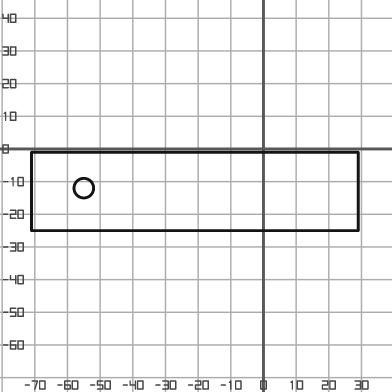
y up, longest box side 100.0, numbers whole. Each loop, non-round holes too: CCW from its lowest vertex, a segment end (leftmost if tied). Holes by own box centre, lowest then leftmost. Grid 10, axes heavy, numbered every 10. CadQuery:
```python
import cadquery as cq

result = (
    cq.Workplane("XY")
    .moveTo(-71.0, -25.0)
    .lineTo(29.0, -25.0)
    .lineTo(29.0, -1.0)
    .lineTo(-71.0, -1.0)
    .close()
    .moveTo(-55.0, -12.0)
    .circle(3.0)
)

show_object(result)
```